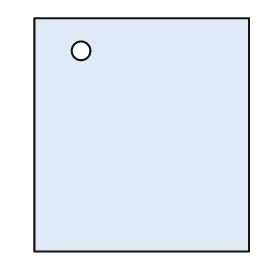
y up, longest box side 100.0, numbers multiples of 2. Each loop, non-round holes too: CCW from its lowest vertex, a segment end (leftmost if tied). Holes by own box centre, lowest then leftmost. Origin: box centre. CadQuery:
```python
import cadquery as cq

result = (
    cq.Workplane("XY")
    .moveTo(-46.0, -50.0)
    .lineTo(46.0, -50.0)
    .lineTo(46.0, 50.0)
    .lineTo(-46.0, 50.0)
    .close()
    .moveTo(-26.0, 36.0)
    .circle(4.0)
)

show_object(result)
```